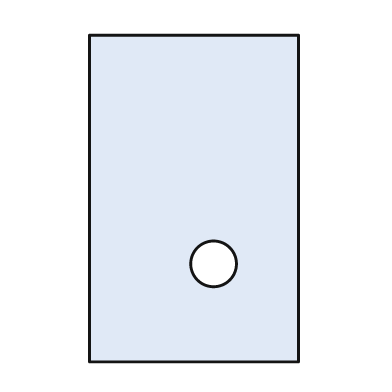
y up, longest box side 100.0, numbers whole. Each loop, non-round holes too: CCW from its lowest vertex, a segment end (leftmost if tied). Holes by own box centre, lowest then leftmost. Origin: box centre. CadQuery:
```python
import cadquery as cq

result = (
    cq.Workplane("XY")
    .moveTo(-32.0, -50.0)
    .lineTo(32.0, -50.0)
    .lineTo(32.0, 50.0)
    .lineTo(-32.0, 50.0)
    .close()
    .moveTo(6.0, -20.0)
    .circle(7.0)
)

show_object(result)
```